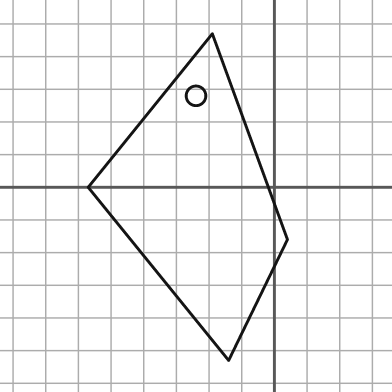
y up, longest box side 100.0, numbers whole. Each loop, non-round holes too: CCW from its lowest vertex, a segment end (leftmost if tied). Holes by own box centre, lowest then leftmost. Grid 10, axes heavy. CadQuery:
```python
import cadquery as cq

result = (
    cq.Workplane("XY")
    .moveTo(-14.0, -53.0)
    .lineTo(4.0, -16.0)
    .lineTo(-19.0, 47.0)
    .lineTo(-57.0, 0.0)
    .close()
    .moveTo(-24.0, 28.0)
    .circle(3.0)
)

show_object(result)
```